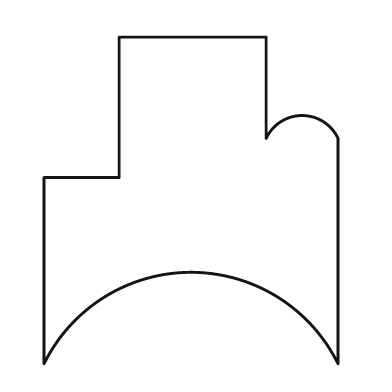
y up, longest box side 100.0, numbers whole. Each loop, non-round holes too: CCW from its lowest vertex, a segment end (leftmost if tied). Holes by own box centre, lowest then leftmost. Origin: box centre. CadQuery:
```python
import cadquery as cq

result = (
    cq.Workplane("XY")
    .moveTo(-45.0, -50.0)
    .threePointArc((0.0, -22.0), (45.0, -50.0))
    .lineTo(45.0, 19.0)
    .threePointArc((34.0, 26.0), (23.0, 19.0))
    .lineTo(23.0, 50.0)
    .lineTo(-22.0, 50.0)
    .lineTo(-22.0, 7.0)
    .lineTo(-45.0, 7.0)
    .close()
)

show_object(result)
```